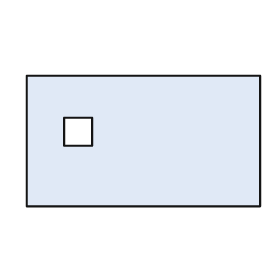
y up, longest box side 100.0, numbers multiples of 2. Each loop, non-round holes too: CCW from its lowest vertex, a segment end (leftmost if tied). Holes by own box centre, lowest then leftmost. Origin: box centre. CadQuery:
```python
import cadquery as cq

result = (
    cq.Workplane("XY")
    .moveTo(-50.0, -28.0)
    .lineTo(50.0, -28.0)
    .lineTo(50.0, 28.0)
    .lineTo(-50.0, 28.0)
    .close()
    .moveTo(-34.0, -2.0)
    .lineTo(-22.0, -2.0)
    .lineTo(-22.0, 10.0)
    .lineTo(-34.0, 10.0)
    .close()
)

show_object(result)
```